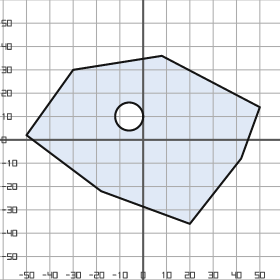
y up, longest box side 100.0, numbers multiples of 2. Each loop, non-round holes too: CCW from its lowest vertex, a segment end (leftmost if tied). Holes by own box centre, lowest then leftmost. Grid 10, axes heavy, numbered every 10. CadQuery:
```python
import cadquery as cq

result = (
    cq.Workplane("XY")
    .moveTo(20.0, -36.0)
    .lineTo(42.0, -8.0)
    .lineTo(50.0, 14.0)
    .lineTo(8.0, 36.0)
    .lineTo(-30.0, 30.0)
    .lineTo(-50.0, 2.0)
    .lineTo(-18.0, -22.0)
    .close()
    .moveTo(-6.0, 10.0)
    .circle(6.0)
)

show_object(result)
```